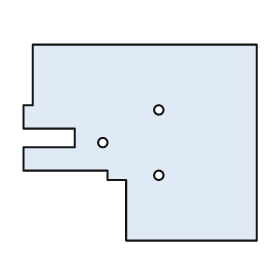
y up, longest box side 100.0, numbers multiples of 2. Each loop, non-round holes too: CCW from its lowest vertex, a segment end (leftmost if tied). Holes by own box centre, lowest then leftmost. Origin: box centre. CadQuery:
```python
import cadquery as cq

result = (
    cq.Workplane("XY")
    .moveTo(-6.0, -42.0)
    .lineTo(50.0, -42.0)
    .lineTo(50.0, 42.0)
    .lineTo(-46.0, 42.0)
    .lineTo(-46.0, 16.0)
    .lineTo(-50.0, 16.0)
    .lineTo(-50.0, 6.0)
    .lineTo(-28.0, 6.0)
    .lineTo(-28.0, -2.0)
    .lineTo(-50.0, -2.0)
    .lineTo(-50.0, -12.0)
    .lineTo(-14.0, -12.0)
    .lineTo(-14.0, -16.0)
    .lineTo(-6.0, -16.0)
    .close()
    .moveTo(8.0, -14.0)
    .circle(2.0)
    .moveTo(-16.0, 0.0)
    .circle(2.0)
    .moveTo(8.0, 14.0)
    .circle(2.0)
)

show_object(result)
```